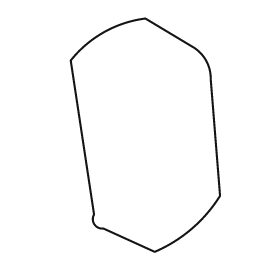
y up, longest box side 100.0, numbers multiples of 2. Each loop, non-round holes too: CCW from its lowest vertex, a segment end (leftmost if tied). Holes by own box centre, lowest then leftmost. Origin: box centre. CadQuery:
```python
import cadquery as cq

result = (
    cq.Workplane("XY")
    .moveTo(4.0, -50.0)
    .threePointArc((20.0, -40.0), (32.0, -26.0))
    .lineTo(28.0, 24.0)
    .threePointArc((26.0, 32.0), (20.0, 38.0))
    .lineTo(0.0, 50.0)
    .threePointArc((-18.0, 44.0), (-32.0, 32.0))
    .lineTo(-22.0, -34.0)
    .threePointArc((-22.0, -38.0), (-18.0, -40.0))
    .close()
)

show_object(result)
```